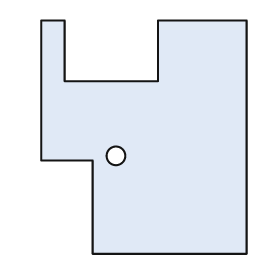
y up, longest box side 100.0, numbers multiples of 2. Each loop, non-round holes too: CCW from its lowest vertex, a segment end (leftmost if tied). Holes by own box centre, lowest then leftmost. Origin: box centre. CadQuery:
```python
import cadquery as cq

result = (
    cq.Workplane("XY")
    .moveTo(-22.0, -50.0)
    .lineTo(44.0, -50.0)
    .lineTo(44.0, 50.0)
    .lineTo(6.0, 50.0)
    .lineTo(6.0, 24.0)
    .lineTo(-34.0, 24.0)
    .lineTo(-34.0, 50.0)
    .lineTo(-44.0, 50.0)
    .lineTo(-44.0, -10.0)
    .lineTo(-22.0, -10.0)
    .close()
    .moveTo(-12.0, -8.0)
    .circle(4.0)
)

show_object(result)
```